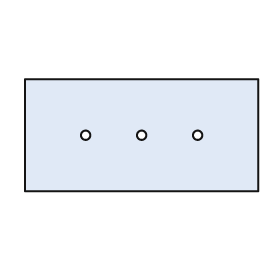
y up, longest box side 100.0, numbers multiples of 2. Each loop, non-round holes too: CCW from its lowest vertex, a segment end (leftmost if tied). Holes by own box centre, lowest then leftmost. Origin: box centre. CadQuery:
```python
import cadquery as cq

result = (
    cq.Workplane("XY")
    .moveTo(-50.0, -24.0)
    .lineTo(50.0, -24.0)
    .lineTo(50.0, 24.0)
    .lineTo(-50.0, 24.0)
    .close()
    .moveTo(-24.0, 0.0)
    .circle(2.0)
    .moveTo(0.0, 0.0)
    .circle(2.0)
    .moveTo(24.0, 0.0)
    .circle(2.0)
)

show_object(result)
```